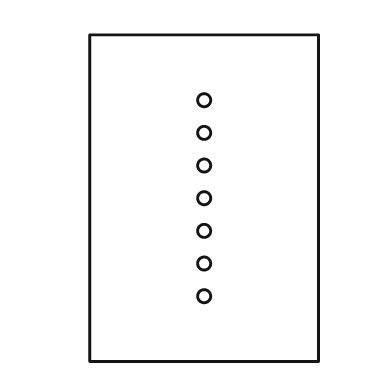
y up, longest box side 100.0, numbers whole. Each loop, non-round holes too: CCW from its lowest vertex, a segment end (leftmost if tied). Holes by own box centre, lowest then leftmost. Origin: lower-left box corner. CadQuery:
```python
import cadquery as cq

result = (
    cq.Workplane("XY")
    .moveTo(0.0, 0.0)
    .lineTo(70.0, 0.0)
    .lineTo(70.0, 100.0)
    .lineTo(0.0, 100.0)
    .close()
    .moveTo(35.0, 20.0)
    .circle(2.0)
    .moveTo(35.0, 30.0)
    .circle(2.0)
    .moveTo(35.0, 40.0)
    .circle(2.0)
    .moveTo(35.0, 50.0)
    .circle(2.0)
    .moveTo(35.0, 60.0)
    .circle(2.0)
    .moveTo(35.0, 70.0)
    .circle(2.0)
    .moveTo(35.0, 80.0)
    .circle(2.0)
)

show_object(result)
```